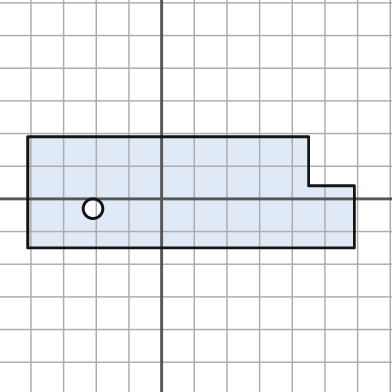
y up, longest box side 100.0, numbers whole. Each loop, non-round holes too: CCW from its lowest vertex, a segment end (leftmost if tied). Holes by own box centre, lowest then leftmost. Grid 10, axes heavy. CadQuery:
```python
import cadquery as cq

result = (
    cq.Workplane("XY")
    .moveTo(-41.0, -15.0)
    .lineTo(59.0, -15.0)
    .lineTo(59.0, 4.0)
    .lineTo(45.0, 4.0)
    .lineTo(45.0, 19.0)
    .lineTo(-41.0, 19.0)
    .close()
    .moveTo(-21.0, -3.0)
    .circle(3.0)
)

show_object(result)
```